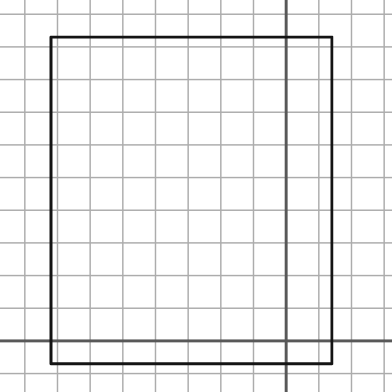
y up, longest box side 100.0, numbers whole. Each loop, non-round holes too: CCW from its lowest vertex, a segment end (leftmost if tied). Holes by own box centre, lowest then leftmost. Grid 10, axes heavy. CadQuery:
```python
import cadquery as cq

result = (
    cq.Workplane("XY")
    .moveTo(-72.0, -7.0)
    .lineTo(14.0, -7.0)
    .lineTo(14.0, 93.0)
    .lineTo(-72.0, 93.0)
    .close()
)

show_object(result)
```